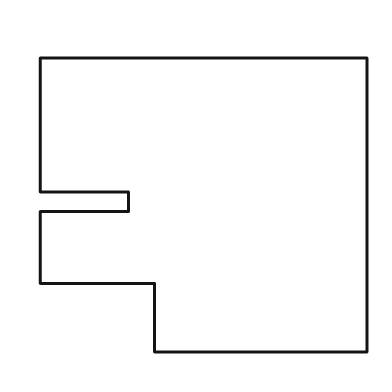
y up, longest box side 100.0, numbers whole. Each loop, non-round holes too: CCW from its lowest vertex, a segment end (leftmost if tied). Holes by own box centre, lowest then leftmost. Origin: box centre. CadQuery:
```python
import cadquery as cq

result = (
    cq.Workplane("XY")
    .moveTo(-15.0, -45.0)
    .lineTo(50.0, -45.0)
    .lineTo(50.0, 45.0)
    .lineTo(-50.0, 45.0)
    .lineTo(-50.0, 4.0)
    .lineTo(-23.0, 4.0)
    .lineTo(-23.0, -2.0)
    .lineTo(-50.0, -2.0)
    .lineTo(-50.0, -24.0)
    .lineTo(-15.0, -24.0)
    .close()
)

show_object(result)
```